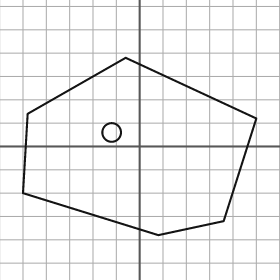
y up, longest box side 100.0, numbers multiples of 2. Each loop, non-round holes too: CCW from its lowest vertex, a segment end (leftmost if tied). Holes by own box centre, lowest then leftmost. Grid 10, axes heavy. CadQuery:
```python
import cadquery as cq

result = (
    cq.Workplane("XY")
    .moveTo(8.0, -38.0)
    .lineTo(36.0, -32.0)
    .lineTo(50.0, 12.0)
    .lineTo(-6.0, 38.0)
    .lineTo(-48.0, 14.0)
    .lineTo(-50.0, -20.0)
    .close()
    .moveTo(-12.0, 6.0)
    .circle(4.0)
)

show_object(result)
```